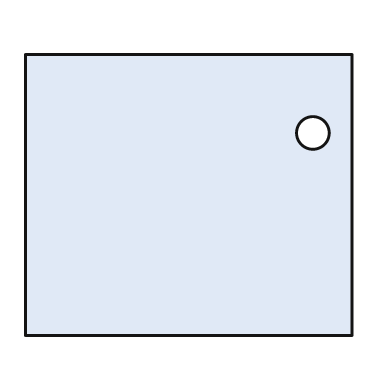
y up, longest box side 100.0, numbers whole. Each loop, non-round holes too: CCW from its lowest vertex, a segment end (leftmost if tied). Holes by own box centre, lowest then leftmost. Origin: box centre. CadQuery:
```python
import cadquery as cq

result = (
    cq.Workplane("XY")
    .moveTo(-50.0, -43.0)
    .lineTo(50.0, -43.0)
    .lineTo(50.0, 43.0)
    .lineTo(-50.0, 43.0)
    .close()
    .moveTo(38.0, 19.0)
    .circle(5.0)
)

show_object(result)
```